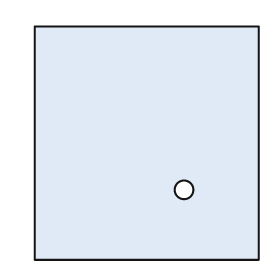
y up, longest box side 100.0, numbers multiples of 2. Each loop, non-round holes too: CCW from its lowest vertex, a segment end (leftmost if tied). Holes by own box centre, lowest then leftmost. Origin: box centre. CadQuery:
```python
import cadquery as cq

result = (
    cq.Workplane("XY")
    .moveTo(-48.0, -50.0)
    .lineTo(48.0, -50.0)
    .lineTo(48.0, 50.0)
    .lineTo(-48.0, 50.0)
    .close()
    .moveTo(16.0, -20.0)
    .circle(4.0)
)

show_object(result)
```